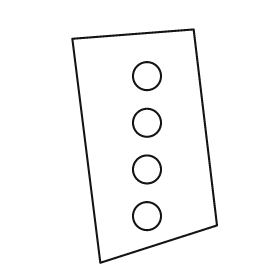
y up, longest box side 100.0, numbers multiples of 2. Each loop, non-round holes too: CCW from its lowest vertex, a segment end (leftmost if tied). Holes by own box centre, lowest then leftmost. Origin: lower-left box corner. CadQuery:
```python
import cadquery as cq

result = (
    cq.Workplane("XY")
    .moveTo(12.0, 0.0)
    .lineTo(62.0, 16.0)
    .lineTo(52.0, 100.0)
    .lineTo(0.0, 96.0)
    .close()
    .moveTo(32.0, 20.0)
    .circle(6.0)
    .moveTo(32.0, 40.0)
    .circle(6.0)
    .moveTo(32.0, 60.0)
    .circle(6.0)
    .moveTo(32.0, 80.0)
    .circle(6.0)
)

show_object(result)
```